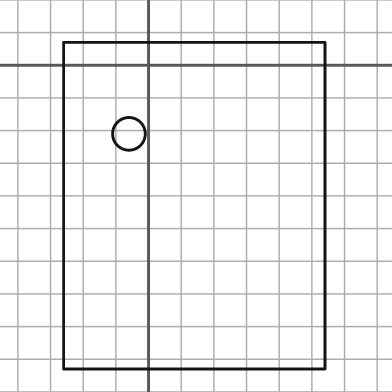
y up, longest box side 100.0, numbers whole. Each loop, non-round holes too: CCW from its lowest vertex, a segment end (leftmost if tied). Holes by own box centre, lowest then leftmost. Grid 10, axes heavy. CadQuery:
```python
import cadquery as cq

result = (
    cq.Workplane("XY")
    .moveTo(-26.0, -93.0)
    .lineTo(54.0, -93.0)
    .lineTo(54.0, 7.0)
    .lineTo(-26.0, 7.0)
    .close()
    .moveTo(-6.0, -21.0)
    .circle(5.0)
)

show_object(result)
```